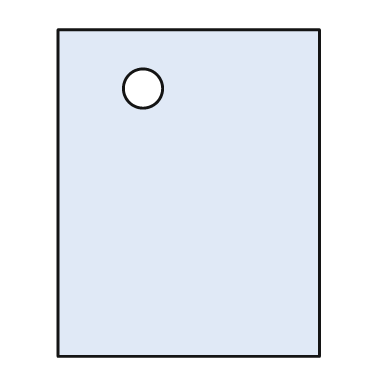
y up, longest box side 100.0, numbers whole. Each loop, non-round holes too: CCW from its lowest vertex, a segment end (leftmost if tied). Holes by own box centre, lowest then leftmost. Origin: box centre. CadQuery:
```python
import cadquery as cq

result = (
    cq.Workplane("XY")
    .moveTo(-40.0, -50.0)
    .lineTo(40.0, -50.0)
    .lineTo(40.0, 50.0)
    .lineTo(-40.0, 50.0)
    .close()
    .moveTo(-14.0, 32.0)
    .circle(6.0)
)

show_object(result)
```